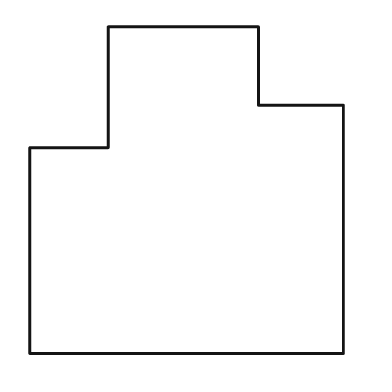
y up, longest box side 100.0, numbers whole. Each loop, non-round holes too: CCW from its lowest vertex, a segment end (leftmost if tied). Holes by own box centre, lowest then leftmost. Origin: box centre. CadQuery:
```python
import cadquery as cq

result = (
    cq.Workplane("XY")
    .moveTo(-48.0, -50.0)
    .lineTo(48.0, -50.0)
    .lineTo(48.0, 26.0)
    .lineTo(22.0, 26.0)
    .lineTo(22.0, 50.0)
    .lineTo(-24.0, 50.0)
    .lineTo(-24.0, 13.0)
    .lineTo(-48.0, 13.0)
    .close()
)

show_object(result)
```